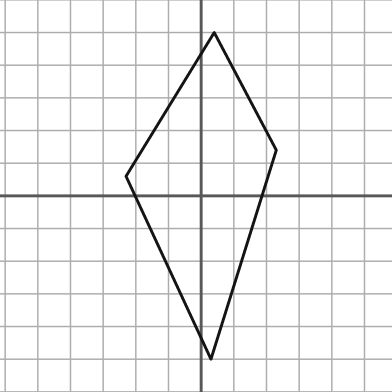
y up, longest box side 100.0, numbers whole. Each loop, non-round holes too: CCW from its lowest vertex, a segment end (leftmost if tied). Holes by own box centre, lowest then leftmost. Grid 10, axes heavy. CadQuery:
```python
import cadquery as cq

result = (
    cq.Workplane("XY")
    .moveTo(3.0, -50.0)
    .lineTo(23.0, 14.0)
    .lineTo(4.0, 50.0)
    .lineTo(-23.0, 6.0)
    .close()
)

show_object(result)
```